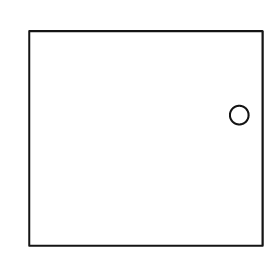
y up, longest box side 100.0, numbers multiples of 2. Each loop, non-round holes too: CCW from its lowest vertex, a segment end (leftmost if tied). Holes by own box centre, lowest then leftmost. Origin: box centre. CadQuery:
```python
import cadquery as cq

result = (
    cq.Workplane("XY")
    .moveTo(-50.0, -46.0)
    .lineTo(50.0, -46.0)
    .lineTo(50.0, 46.0)
    .lineTo(-50.0, 46.0)
    .close()
    .moveTo(40.0, 10.0)
    .circle(4.0)
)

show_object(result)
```